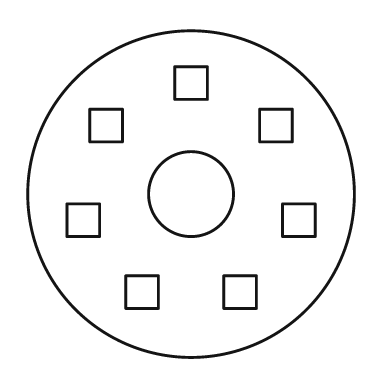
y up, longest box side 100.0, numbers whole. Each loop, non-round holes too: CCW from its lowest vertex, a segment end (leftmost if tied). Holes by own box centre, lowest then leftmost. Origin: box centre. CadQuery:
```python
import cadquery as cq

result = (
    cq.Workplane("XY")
    .moveTo(0.0, 0.0)
    .circle(50.0)
    .moveTo(-20.0, -35.0)
    .lineTo(-10.0, -35.0)
    .lineTo(-10.0, -25.0)
    .lineTo(-20.0, -25.0)
    .close()
    .moveTo(10.0, -35.0)
    .lineTo(20.0, -35.0)
    .lineTo(20.0, -25.0)
    .lineTo(10.0, -25.0)
    .close()
    .moveTo(-38.0, -13.0)
    .lineTo(-28.0, -13.0)
    .lineTo(-28.0, -3.0)
    .lineTo(-38.0, -3.0)
    .close()
    .moveTo(28.0, -13.0)
    .lineTo(38.0, -13.0)
    .lineTo(38.0, -3.0)
    .lineTo(28.0, -3.0)
    .close()
    .moveTo(0.0, 0.0)
    .circle(13.0)
    .moveTo(-31.0, 16.0)
    .lineTo(-21.0, 16.0)
    .lineTo(-21.0, 26.0)
    .lineTo(-31.0, 26.0)
    .close()
    .moveTo(21.0, 16.0)
    .lineTo(31.0, 16.0)
    .lineTo(31.0, 26.0)
    .lineTo(21.0, 26.0)
    .close()
    .moveTo(-5.0, 29.0)
    .lineTo(5.0, 29.0)
    .lineTo(5.0, 39.0)
    .lineTo(-5.0, 39.0)
    .close()
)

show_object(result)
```